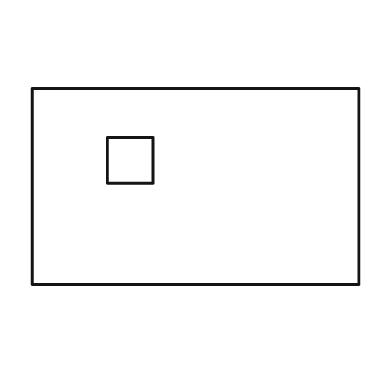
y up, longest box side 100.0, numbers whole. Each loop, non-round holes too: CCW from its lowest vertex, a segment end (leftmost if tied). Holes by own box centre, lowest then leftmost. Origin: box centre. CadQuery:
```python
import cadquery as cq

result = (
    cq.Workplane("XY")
    .moveTo(-50.0, -30.0)
    .lineTo(50.0, -30.0)
    .lineTo(50.0, 30.0)
    .lineTo(-50.0, 30.0)
    .close()
    .moveTo(-27.0, 1.0)
    .lineTo(-13.0, 1.0)
    .lineTo(-13.0, 15.0)
    .lineTo(-27.0, 15.0)
    .close()
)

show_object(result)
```